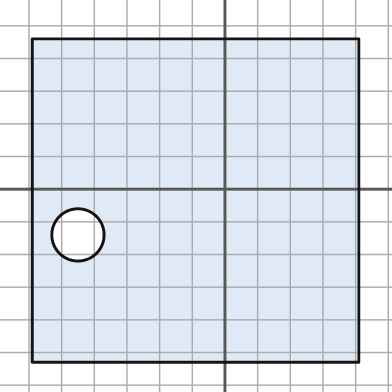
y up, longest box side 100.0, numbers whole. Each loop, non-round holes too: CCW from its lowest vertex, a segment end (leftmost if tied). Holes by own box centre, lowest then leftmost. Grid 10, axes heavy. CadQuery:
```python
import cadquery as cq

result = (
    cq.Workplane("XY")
    .moveTo(-59.0, -53.0)
    .lineTo(41.0, -53.0)
    .lineTo(41.0, 46.0)
    .lineTo(-59.0, 46.0)
    .close()
    .moveTo(-45.0, -14.0)
    .circle(8.0)
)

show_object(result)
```